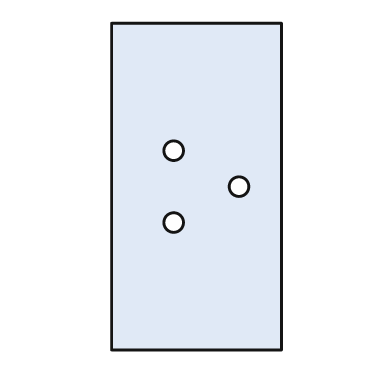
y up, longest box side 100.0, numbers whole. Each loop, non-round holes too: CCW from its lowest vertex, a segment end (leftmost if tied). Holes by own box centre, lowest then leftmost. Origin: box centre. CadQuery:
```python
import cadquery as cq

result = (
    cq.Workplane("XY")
    .moveTo(-26.0, -50.0)
    .lineTo(26.0, -50.0)
    .lineTo(26.0, 50.0)
    .lineTo(-26.0, 50.0)
    .close()
    .moveTo(-7.0, -11.0)
    .circle(3.0)
    .moveTo(13.0, 0.0)
    .circle(3.0)
    .moveTo(-7.0, 11.0)
    .circle(3.0)
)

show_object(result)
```